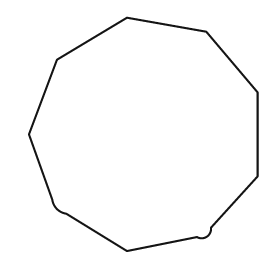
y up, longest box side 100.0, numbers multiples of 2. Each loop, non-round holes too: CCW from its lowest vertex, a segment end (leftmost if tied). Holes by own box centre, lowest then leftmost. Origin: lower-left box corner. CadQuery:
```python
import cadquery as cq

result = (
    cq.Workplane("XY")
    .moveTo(42.0, 0.0)
    .lineTo(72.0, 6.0)
    .threePointArc((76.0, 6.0), (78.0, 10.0))
    .lineTo(98.0, 32.0)
    .lineTo(98.0, 68.0)
    .lineTo(76.0, 94.0)
    .lineTo(42.0, 100.0)
    .lineTo(12.0, 82.0)
    .lineTo(0.0, 50.0)
    .lineTo(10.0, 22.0)
    .threePointArc((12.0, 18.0), (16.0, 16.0))
    .close()
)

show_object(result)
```